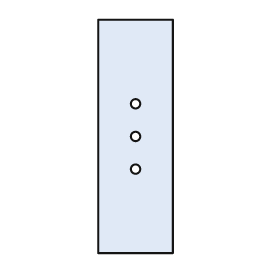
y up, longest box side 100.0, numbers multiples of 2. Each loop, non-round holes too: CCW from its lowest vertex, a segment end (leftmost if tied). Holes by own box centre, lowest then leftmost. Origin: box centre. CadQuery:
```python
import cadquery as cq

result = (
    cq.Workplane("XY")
    .moveTo(-16.0, -50.0)
    .lineTo(16.0, -50.0)
    .lineTo(16.0, 50.0)
    .lineTo(-16.0, 50.0)
    .close()
    .moveTo(0.0, -14.0)
    .circle(2.0)
    .moveTo(0.0, 0.0)
    .circle(2.0)
    .moveTo(0.0, 14.0)
    .circle(2.0)
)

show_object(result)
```